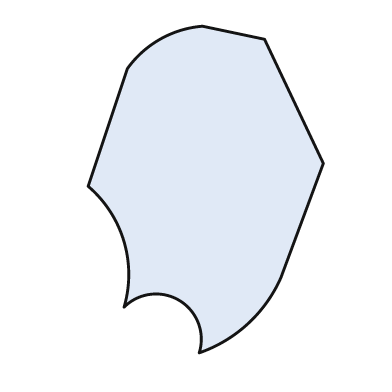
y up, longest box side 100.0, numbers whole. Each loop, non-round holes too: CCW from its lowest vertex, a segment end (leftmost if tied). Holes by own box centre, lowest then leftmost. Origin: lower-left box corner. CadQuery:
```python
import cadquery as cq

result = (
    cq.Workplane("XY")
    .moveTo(34.0, 0.0)
    .threePointArc((49.0, 9.0), (59.0, 23.0))
    .lineTo(72.0, 58.0)
    .lineTo(54.0, 96.0)
    .lineTo(35.0, 100.0)
    .threePointArc((22.0, 96.0), (12.0, 87.0))
    .lineTo(0.0, 51.0)
    .threePointArc((11.0, 34.0), (11.0, 14.0))
    .threePointArc((28.0, 16.0), (34.0, 0.0))
    .close()
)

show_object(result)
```